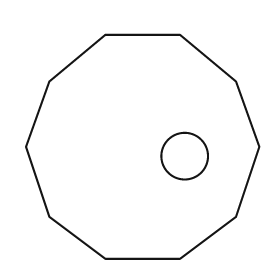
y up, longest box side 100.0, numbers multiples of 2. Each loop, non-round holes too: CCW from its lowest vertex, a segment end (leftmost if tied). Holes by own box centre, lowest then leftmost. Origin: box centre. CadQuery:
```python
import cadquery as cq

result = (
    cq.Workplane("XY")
    .moveTo(-16.0, -48.0)
    .lineTo(16.0, -48.0)
    .lineTo(40.0, -30.0)
    .lineTo(50.0, 0.0)
    .lineTo(40.0, 28.0)
    .lineTo(16.0, 48.0)
    .lineTo(-16.0, 48.0)
    .lineTo(-40.0, 28.0)
    .lineTo(-50.0, 0.0)
    .lineTo(-40.0, -30.0)
    .close()
    .moveTo(18.0, -4.0)
    .circle(10.0)
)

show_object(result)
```